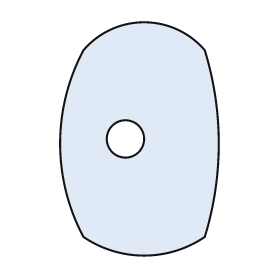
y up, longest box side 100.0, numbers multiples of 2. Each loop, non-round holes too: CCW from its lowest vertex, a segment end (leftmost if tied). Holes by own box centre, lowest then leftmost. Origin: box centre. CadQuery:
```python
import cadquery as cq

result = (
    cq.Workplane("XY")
    .moveTo(-24.0, -42.0)
    .threePointArc((2.0, -50.0), (28.0, -42.0))
    .threePointArc((34.0, -2.0), (28.0, 38.0))
    .threePointArc((2.0, 50.0), (-24.0, 38.0))
    .threePointArc((-34.0, -2.0), (-24.0, -42.0))
    .close()
    .moveTo(-6.0, 0.0)
    .circle(8.0)
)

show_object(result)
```